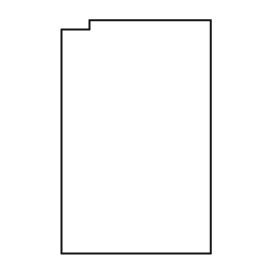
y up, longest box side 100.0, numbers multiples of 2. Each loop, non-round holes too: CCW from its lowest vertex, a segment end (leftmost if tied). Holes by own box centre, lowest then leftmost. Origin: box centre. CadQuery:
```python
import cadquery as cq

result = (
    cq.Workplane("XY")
    .moveTo(-32.0, -50.0)
    .lineTo(32.0, -50.0)
    .lineTo(32.0, 50.0)
    .lineTo(-20.0, 50.0)
    .lineTo(-20.0, 46.0)
    .lineTo(-32.0, 46.0)
    .close()
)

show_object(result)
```